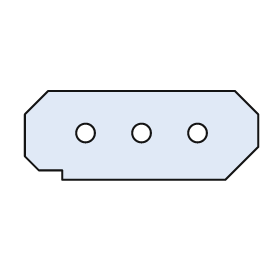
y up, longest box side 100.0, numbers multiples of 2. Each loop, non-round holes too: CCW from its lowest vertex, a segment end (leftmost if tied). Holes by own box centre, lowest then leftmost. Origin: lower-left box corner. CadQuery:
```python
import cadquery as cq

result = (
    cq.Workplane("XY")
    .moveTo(16.0, 0.0)
    .lineTo(86.0, 0.0)
    .lineTo(100.0, 14.0)
    .lineTo(100.0, 28.0)
    .lineTo(90.0, 38.0)
    .lineTo(10.0, 38.0)
    .lineTo(0.0, 28.0)
    .lineTo(0.0, 10.0)
    .lineTo(6.0, 4.0)
    .lineTo(16.0, 4.0)
    .close()
    .moveTo(26.0, 20.0)
    .circle(4.0)
    .moveTo(50.0, 20.0)
    .circle(4.0)
    .moveTo(74.0, 20.0)
    .circle(4.0)
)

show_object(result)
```